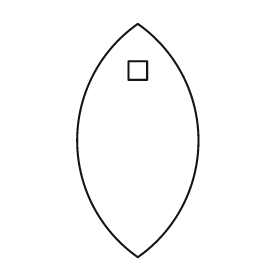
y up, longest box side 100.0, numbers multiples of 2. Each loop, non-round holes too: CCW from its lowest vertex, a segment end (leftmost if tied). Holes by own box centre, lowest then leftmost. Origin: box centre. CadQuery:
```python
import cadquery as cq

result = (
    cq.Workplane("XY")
    .moveTo(0.0, -50.0)
    .threePointArc((26.0, 0.0), (0.0, 50.0))
    .threePointArc((-26.0, 0.0), (0.0, -50.0))
    .close()
    .moveTo(-4.0, 26.0)
    .lineTo(4.0, 26.0)
    .lineTo(4.0, 34.0)
    .lineTo(-4.0, 34.0)
    .close()
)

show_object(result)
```